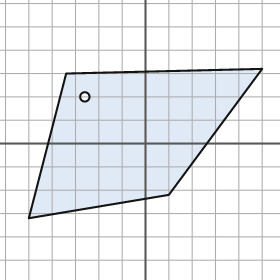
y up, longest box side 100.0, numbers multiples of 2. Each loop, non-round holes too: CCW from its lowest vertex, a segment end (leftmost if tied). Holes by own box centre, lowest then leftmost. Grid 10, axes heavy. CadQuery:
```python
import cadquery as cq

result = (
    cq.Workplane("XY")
    .moveTo(-50.0, -32.0)
    .lineTo(10.0, -22.0)
    .lineTo(50.0, 32.0)
    .lineTo(-34.0, 30.0)
    .close()
    .moveTo(-26.0, 20.0)
    .circle(2.0)
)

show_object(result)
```